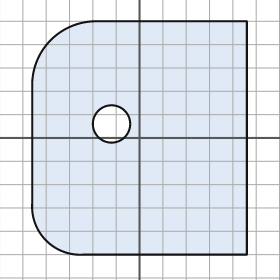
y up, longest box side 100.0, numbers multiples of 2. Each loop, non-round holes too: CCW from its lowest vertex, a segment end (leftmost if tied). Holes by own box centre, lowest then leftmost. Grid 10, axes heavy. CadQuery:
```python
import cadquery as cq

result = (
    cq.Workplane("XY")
    .moveTo(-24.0, -50.0)
    .lineTo(46.0, -50.0)
    .lineTo(46.0, 50.0)
    .lineTo(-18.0, 50.0)
    .threePointArc((-38.0, 42.0), (-46.0, 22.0))
    .lineTo(-46.0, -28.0)
    .threePointArc((-40.0, -44.0), (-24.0, -50.0))
    .close()
    .moveTo(-12.0, 6.0)
    .circle(8.0)
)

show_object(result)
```